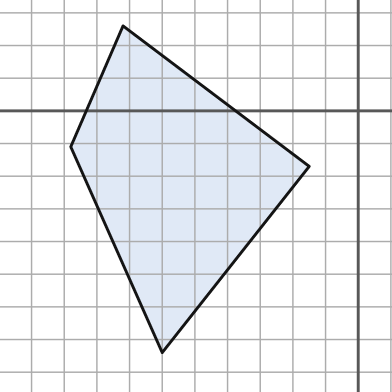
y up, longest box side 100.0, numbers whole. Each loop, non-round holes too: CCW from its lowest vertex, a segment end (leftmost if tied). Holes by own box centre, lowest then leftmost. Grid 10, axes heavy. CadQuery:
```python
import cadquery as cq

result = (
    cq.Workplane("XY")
    .moveTo(-60.0, -74.0)
    .lineTo(-15.0, -17.0)
    .lineTo(-72.0, 26.0)
    .lineTo(-88.0, -11.0)
    .close()
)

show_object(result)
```